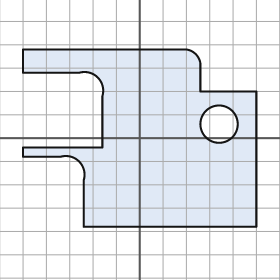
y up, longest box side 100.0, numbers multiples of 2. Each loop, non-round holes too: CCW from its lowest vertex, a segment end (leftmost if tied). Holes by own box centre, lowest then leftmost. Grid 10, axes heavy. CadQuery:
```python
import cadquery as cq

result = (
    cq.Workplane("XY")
    .moveTo(-24.0, -38.0)
    .lineTo(50.0, -38.0)
    .lineTo(50.0, 20.0)
    .lineTo(26.0, 20.0)
    .lineTo(26.0, 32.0)
    .threePointArc((24.0, 36.0), (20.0, 38.0))
    .lineTo(-50.0, 38.0)
    .lineTo(-50.0, 28.0)
    .lineTo(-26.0, 28.0)
    .threePointArc((-18.0, 26.0), (-16.0, 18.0))
    .lineTo(-16.0, -4.0)
    .lineTo(-50.0, -4.0)
    .lineTo(-50.0, -8.0)
    .lineTo(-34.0, -8.0)
    .threePointArc((-26.0, -10.0), (-24.0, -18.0))
    .close()
    .moveTo(34.0, 6.0)
    .circle(8.0)
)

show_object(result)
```